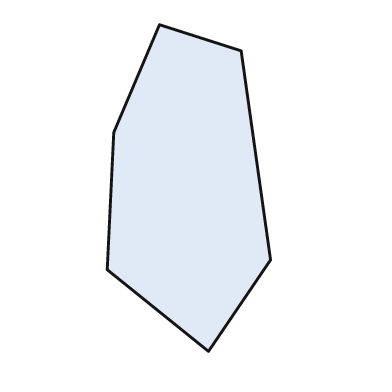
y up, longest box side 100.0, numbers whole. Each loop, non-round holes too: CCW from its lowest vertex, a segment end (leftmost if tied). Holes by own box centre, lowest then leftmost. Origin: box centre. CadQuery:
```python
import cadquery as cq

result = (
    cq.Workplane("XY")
    .moveTo(6.0, -50.0)
    .lineTo(25.0, -22.0)
    .lineTo(16.0, 42.0)
    .lineTo(-9.0, 50.0)
    .lineTo(-23.0, 17.0)
    .lineTo(-25.0, -25.0)
    .close()
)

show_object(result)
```